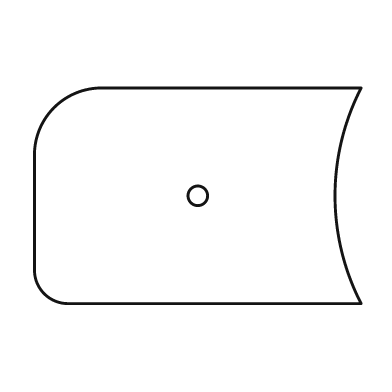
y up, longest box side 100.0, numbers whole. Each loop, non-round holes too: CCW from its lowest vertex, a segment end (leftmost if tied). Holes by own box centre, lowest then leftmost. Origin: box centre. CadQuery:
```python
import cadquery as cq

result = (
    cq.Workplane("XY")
    .moveTo(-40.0, -33.0)
    .lineTo(50.0, -33.0)
    .threePointArc((42.0, 0.0), (50.0, 33.0))
    .lineTo(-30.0, 33.0)
    .threePointArc((-44.0, 27.0), (-50.0, 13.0))
    .lineTo(-50.0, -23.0)
    .threePointArc((-47.0, -30.0), (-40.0, -33.0))
    .close()
    .moveTo(0.0, 0.0)
    .circle(3.0)
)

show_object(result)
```